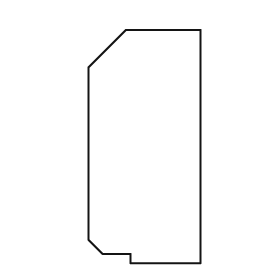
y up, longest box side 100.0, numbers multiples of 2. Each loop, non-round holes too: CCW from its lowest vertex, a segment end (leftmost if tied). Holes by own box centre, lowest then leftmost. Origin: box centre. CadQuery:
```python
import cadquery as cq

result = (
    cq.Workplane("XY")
    .moveTo(-6.0, -50.0)
    .lineTo(24.0, -50.0)
    .lineTo(24.0, 50.0)
    .lineTo(-8.0, 50.0)
    .lineTo(-24.0, 34.0)
    .lineTo(-24.0, -40.0)
    .lineTo(-18.0, -46.0)
    .lineTo(-6.0, -46.0)
    .close()
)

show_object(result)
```